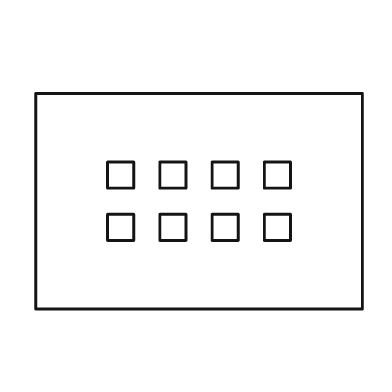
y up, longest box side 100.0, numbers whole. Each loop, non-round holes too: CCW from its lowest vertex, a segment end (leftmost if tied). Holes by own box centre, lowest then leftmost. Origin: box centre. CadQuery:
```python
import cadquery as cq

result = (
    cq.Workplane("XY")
    .moveTo(-50.0, -33.0)
    .lineTo(50.0, -33.0)
    .lineTo(50.0, 33.0)
    .lineTo(-50.0, 33.0)
    .close()
    .moveTo(-28.0, -12.0)
    .lineTo(-20.0, -12.0)
    .lineTo(-20.0, -4.0)
    .lineTo(-28.0, -4.0)
    .close()
    .moveTo(-12.0, -12.0)
    .lineTo(-4.0, -12.0)
    .lineTo(-4.0, -4.0)
    .lineTo(-12.0, -4.0)
    .close()
    .moveTo(4.0, -12.0)
    .lineTo(12.0, -12.0)
    .lineTo(12.0, -4.0)
    .lineTo(4.0, -4.0)
    .close()
    .moveTo(20.0, -12.0)
    .lineTo(28.0, -12.0)
    .lineTo(28.0, -4.0)
    .lineTo(20.0, -4.0)
    .close()
    .moveTo(-28.0, 4.0)
    .lineTo(-20.0, 4.0)
    .lineTo(-20.0, 12.0)
    .lineTo(-28.0, 12.0)
    .close()
    .moveTo(-12.0, 4.0)
    .lineTo(-4.0, 4.0)
    .lineTo(-4.0, 12.0)
    .lineTo(-12.0, 12.0)
    .close()
    .moveTo(4.0, 4.0)
    .lineTo(12.0, 4.0)
    .lineTo(12.0, 12.0)
    .lineTo(4.0, 12.0)
    .close()
    .moveTo(20.0, 4.0)
    .lineTo(28.0, 4.0)
    .lineTo(28.0, 12.0)
    .lineTo(20.0, 12.0)
    .close()
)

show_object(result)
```